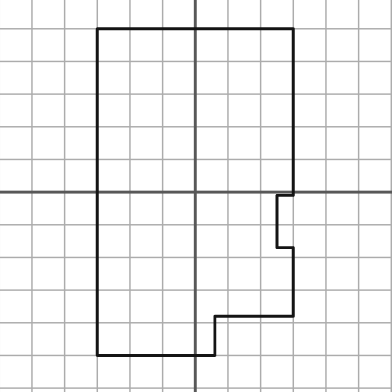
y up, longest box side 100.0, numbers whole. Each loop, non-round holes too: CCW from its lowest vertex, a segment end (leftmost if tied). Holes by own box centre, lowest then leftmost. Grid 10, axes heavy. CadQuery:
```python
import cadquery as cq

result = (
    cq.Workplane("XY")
    .moveTo(-30.0, -50.0)
    .lineTo(6.0, -50.0)
    .lineTo(6.0, -38.0)
    .lineTo(30.0, -38.0)
    .lineTo(30.0, -17.0)
    .lineTo(25.0, -17.0)
    .lineTo(25.0, -1.0)
    .lineTo(30.0, -1.0)
    .lineTo(30.0, 50.0)
    .lineTo(-30.0, 50.0)
    .close()
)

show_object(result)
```